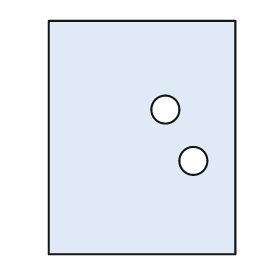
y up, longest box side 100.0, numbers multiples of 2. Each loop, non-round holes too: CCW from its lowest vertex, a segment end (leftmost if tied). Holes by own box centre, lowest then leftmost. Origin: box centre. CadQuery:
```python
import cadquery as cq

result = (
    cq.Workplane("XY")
    .moveTo(-40.0, -50.0)
    .lineTo(40.0, -50.0)
    .lineTo(40.0, 50.0)
    .lineTo(-40.0, 50.0)
    .close()
    .moveTo(22.0, -10.0)
    .circle(6.0)
    .moveTo(10.0, 12.0)
    .circle(6.0)
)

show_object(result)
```